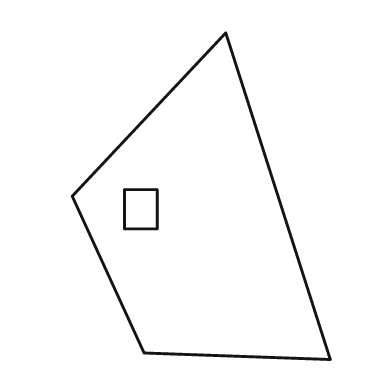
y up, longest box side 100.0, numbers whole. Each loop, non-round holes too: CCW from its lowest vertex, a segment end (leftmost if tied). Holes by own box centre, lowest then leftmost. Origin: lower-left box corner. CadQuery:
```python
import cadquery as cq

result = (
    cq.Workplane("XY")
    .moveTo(79.0, 0.0)
    .lineTo(47.0, 100.0)
    .lineTo(0.0, 50.0)
    .lineTo(22.0, 2.0)
    .close()
    .moveTo(16.0, 40.0)
    .lineTo(26.0, 40.0)
    .lineTo(26.0, 52.0)
    .lineTo(16.0, 52.0)
    .close()
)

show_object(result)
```